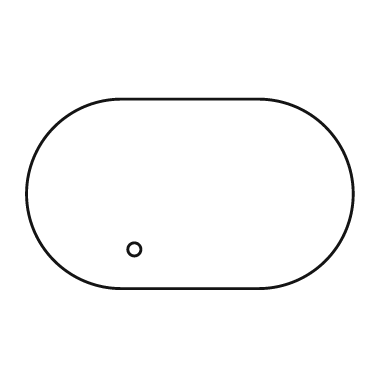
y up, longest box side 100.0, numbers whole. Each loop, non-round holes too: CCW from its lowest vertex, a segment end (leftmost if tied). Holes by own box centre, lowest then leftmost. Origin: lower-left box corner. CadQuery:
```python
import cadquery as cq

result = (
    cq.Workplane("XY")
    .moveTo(29.0, 0.0)
    .lineTo(71.0, 0.0)
    .threePointArc((100.0, 29.0), (71.0, 58.0))
    .lineTo(29.0, 58.0)
    .threePointArc((0.0, 29.0), (29.0, 0.0))
    .close()
    .moveTo(33.0, 12.0)
    .circle(2.0)
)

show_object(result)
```